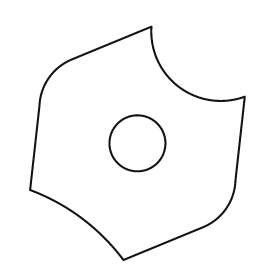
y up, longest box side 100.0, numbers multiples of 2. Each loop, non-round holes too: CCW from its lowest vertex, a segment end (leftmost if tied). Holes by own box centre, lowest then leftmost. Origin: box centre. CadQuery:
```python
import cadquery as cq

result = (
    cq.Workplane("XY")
    .moveTo(-6.0, -50.0)
    .lineTo(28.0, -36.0)
    .threePointArc((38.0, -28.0), (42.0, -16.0))
    .lineTo(46.0, 20.0)
    .threePointArc((18.0, 24.0), (6.0, 50.0))
    .lineTo(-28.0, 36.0)
    .threePointArc((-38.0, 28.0), (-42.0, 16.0))
    .lineTo(-46.0, -20.0)
    .threePointArc((-24.0, -32.0), (-6.0, -50.0))
    .close()
    .moveTo(0.0, 0.0)
    .circle(12.0)
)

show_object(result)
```